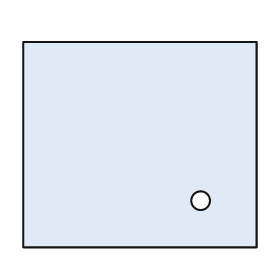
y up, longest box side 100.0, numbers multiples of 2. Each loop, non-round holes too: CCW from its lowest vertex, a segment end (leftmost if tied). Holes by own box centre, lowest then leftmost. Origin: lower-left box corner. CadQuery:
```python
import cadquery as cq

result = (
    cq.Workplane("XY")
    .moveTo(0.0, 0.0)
    .lineTo(100.0, 0.0)
    .lineTo(100.0, 88.0)
    .lineTo(0.0, 88.0)
    .close()
    .moveTo(76.0, 20.0)
    .circle(4.0)
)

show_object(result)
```